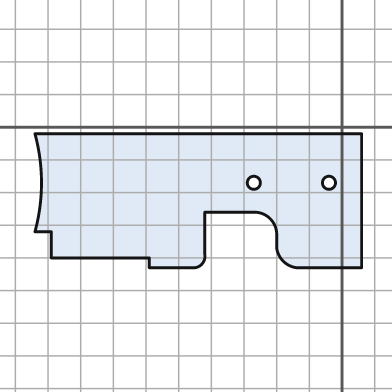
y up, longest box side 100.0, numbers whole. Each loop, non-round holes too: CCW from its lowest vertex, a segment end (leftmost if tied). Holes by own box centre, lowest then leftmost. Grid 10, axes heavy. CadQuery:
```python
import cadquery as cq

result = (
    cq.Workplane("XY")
    .moveTo(-59.0, -43.0)
    .lineTo(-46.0, -43.0)
    .threePointArc((-43.0, -42.0), (-42.0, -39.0))
    .lineTo(-42.0, -26.0)
    .lineTo(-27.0, -26.0)
    .threePointArc((-22.0, -28.0), (-20.0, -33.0))
    .lineTo(-20.0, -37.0)
    .threePointArc((-18.0, -41.0), (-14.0, -43.0))
    .lineTo(6.0, -43.0)
    .lineTo(6.0, -2.0)
    .lineTo(-94.0, -2.0)
    .threePointArc((-92.0, -17.0), (-94.0, -32.0))
    .lineTo(-89.0, -32.0)
    .lineTo(-89.0, -40.0)
    .lineTo(-59.0, -40.0)
    .close()
    .moveTo(-27.0, -17.0)
    .circle(2.0)
    .moveTo(-4.0, -17.0)
    .circle(2.0)
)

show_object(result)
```